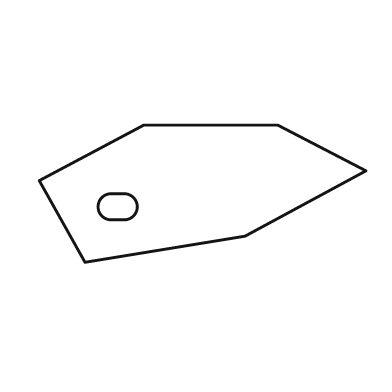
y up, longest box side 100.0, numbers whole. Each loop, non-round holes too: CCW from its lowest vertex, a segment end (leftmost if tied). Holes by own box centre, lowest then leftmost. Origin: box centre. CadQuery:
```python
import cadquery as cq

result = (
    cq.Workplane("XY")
    .moveTo(-36.0, -21.0)
    .lineTo(13.0, -13.0)
    .lineTo(50.0, 7.0)
    .lineTo(23.0, 21.0)
    .lineTo(-18.0, 21.0)
    .lineTo(-50.0, 4.0)
    .close()
    .moveTo(-28.0, -8.0)
    .lineTo(-24.0, -8.0)
    .threePointArc((-20.0, -4.0), (-24.0, 0.0))
    .lineTo(-28.0, 0.0)
    .threePointArc((-32.0, -4.0), (-28.0, -8.0))
    .close()
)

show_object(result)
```